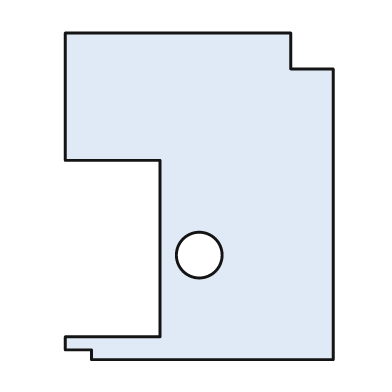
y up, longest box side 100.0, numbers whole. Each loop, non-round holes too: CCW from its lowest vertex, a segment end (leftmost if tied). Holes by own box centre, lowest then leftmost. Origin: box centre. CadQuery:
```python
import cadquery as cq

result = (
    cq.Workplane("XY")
    .moveTo(-33.0, -50.0)
    .lineTo(41.0, -50.0)
    .lineTo(41.0, 39.0)
    .lineTo(28.0, 39.0)
    .lineTo(28.0, 50.0)
    .lineTo(-41.0, 50.0)
    .lineTo(-41.0, 11.0)
    .lineTo(-12.0, 11.0)
    .lineTo(-12.0, -43.0)
    .lineTo(-41.0, -43.0)
    .lineTo(-41.0, -47.0)
    .lineTo(-33.0, -47.0)
    .close()
    .moveTo(0.0, -18.0)
    .circle(7.0)
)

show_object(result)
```